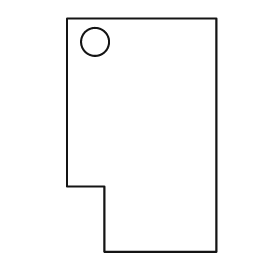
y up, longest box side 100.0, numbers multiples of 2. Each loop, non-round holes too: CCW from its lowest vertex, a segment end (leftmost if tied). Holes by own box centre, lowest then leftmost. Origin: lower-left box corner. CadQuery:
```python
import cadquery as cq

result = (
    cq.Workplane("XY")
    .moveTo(16.0, 0.0)
    .lineTo(64.0, 0.0)
    .lineTo(64.0, 100.0)
    .lineTo(0.0, 100.0)
    .lineTo(0.0, 28.0)
    .lineTo(16.0, 28.0)
    .close()
    .moveTo(12.0, 90.0)
    .circle(6.0)
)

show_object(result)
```